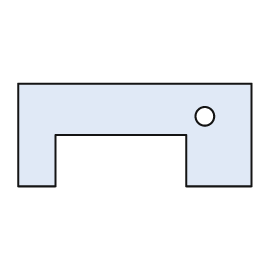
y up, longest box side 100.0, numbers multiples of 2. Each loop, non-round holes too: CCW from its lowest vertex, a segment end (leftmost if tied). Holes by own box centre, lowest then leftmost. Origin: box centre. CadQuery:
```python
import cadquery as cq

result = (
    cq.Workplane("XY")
    .moveTo(-50.0, -22.0)
    .lineTo(-34.0, -22.0)
    .lineTo(-34.0, 0.0)
    .lineTo(22.0, 0.0)
    .lineTo(22.0, -22.0)
    .lineTo(50.0, -22.0)
    .lineTo(50.0, 22.0)
    .lineTo(-50.0, 22.0)
    .close()
    .moveTo(30.0, 8.0)
    .circle(4.0)
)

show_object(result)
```